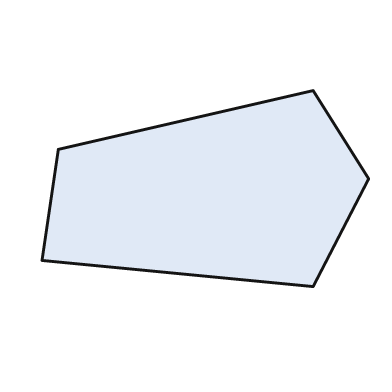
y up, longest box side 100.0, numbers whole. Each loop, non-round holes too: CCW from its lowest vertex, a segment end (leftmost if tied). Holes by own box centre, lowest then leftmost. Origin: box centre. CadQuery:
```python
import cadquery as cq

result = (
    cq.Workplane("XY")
    .moveTo(33.0, -30.0)
    .lineTo(50.0, 3.0)
    .lineTo(33.0, 30.0)
    .lineTo(-45.0, 12.0)
    .lineTo(-50.0, -22.0)
    .close()
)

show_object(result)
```